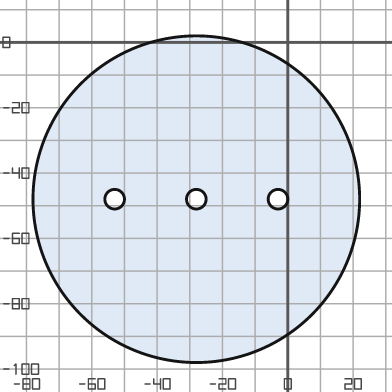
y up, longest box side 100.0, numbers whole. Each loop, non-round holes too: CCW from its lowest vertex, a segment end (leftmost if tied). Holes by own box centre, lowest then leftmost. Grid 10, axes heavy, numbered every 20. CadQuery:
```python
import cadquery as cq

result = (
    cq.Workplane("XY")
    .moveTo(-28.0, -48.0)
    .circle(50.0)
    .moveTo(-53.0, -48.0)
    .circle(3.0)
    .moveTo(-28.0, -48.0)
    .circle(3.0)
    .moveTo(-3.0, -48.0)
    .circle(3.0)
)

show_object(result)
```